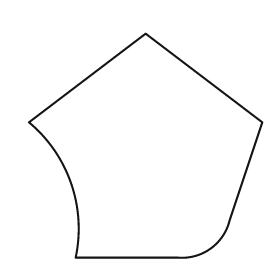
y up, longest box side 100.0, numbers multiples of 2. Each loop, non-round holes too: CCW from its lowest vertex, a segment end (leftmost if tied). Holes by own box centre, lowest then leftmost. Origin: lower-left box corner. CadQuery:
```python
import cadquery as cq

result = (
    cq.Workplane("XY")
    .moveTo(20.0, 0.0)
    .lineTo(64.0, 0.0)
    .threePointArc((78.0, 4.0), (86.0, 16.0))
    .lineTo(100.0, 58.0)
    .lineTo(50.0, 96.0)
    .lineTo(0.0, 58.0)
    .threePointArc((18.0, 32.0), (20.0, 0.0))
    .close()
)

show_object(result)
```